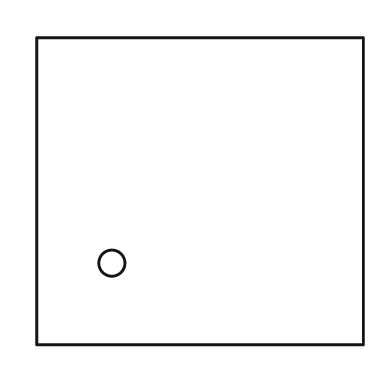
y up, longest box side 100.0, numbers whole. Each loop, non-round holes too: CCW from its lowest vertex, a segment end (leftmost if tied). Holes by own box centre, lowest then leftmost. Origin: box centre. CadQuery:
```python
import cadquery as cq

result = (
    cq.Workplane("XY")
    .moveTo(-50.0, -47.0)
    .lineTo(50.0, -47.0)
    .lineTo(50.0, 47.0)
    .lineTo(-50.0, 47.0)
    .close()
    .moveTo(-27.0, -22.0)
    .circle(4.0)
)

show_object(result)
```